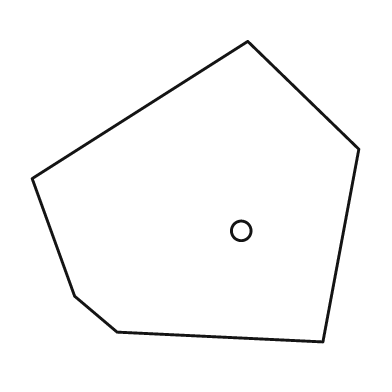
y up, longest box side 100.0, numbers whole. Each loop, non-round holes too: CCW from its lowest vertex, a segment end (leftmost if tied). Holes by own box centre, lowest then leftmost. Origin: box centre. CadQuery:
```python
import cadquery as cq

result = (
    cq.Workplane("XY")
    .moveTo(39.0, -46.0)
    .lineTo(50.0, 13.0)
    .lineTo(16.0, 46.0)
    .lineTo(-50.0, 4.0)
    .lineTo(-37.0, -32.0)
    .lineTo(-24.0, -43.0)
    .close()
    .moveTo(14.0, -12.0)
    .circle(3.0)
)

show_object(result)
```